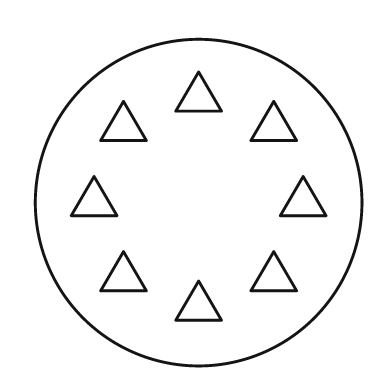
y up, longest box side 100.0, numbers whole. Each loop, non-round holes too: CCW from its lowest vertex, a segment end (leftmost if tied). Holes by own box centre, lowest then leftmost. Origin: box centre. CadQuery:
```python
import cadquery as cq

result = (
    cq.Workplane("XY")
    .moveTo(0.0, 0.0)
    .circle(50.0)
    .moveTo(-7.0, -36.0)
    .lineTo(7.0, -36.0)
    .lineTo(0.0, -24.0)
    .close()
    .moveTo(-30.0, -27.0)
    .lineTo(-16.0, -27.0)
    .lineTo(-23.0, -15.0)
    .close()
    .moveTo(16.0, -27.0)
    .lineTo(30.0, -27.0)
    .lineTo(23.0, -15.0)
    .close()
    .moveTo(-39.0, -4.0)
    .lineTo(-25.0, -4.0)
    .lineTo(-32.0, 8.0)
    .close()
    .moveTo(25.0, -4.0)
    .lineTo(39.0, -4.0)
    .lineTo(32.0, 8.0)
    .close()
    .moveTo(-30.0, 19.0)
    .lineTo(-16.0, 19.0)
    .lineTo(-23.0, 31.0)
    .close()
    .moveTo(16.0, 19.0)
    .lineTo(30.0, 19.0)
    .lineTo(23.0, 31.0)
    .close()
    .moveTo(-7.0, 28.0)
    .lineTo(7.0, 28.0)
    .lineTo(0.0, 40.0)
    .close()
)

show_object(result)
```